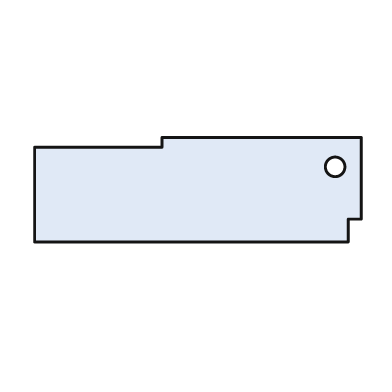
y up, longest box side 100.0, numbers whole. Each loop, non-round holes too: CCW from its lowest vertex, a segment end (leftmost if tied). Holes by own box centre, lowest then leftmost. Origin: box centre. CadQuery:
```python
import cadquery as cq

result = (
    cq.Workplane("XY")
    .moveTo(-50.0, -16.0)
    .lineTo(46.0, -16.0)
    .lineTo(46.0, -9.0)
    .lineTo(50.0, -9.0)
    .lineTo(50.0, 16.0)
    .lineTo(-11.0, 16.0)
    .lineTo(-11.0, 13.0)
    .lineTo(-50.0, 13.0)
    .close()
    .moveTo(42.0, 7.0)
    .circle(3.0)
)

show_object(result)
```